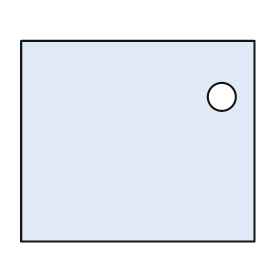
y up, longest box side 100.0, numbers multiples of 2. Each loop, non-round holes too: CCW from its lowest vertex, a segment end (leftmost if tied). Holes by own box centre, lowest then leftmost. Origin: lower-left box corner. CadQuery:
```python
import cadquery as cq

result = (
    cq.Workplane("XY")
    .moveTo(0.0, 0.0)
    .lineTo(100.0, 0.0)
    .lineTo(100.0, 86.0)
    .lineTo(0.0, 86.0)
    .close()
    .moveTo(86.0, 62.0)
    .circle(6.0)
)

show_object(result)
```